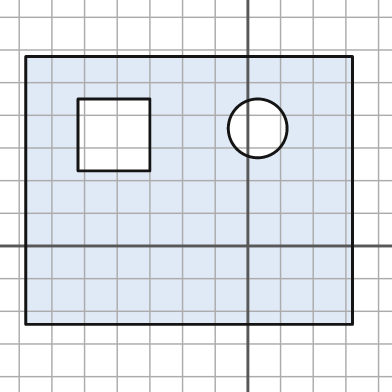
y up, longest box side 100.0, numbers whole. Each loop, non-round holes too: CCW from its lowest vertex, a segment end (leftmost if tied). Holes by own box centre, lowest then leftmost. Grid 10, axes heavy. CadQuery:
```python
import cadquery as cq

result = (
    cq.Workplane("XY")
    .moveTo(-68.0, -24.0)
    .lineTo(32.0, -24.0)
    .lineTo(32.0, 58.0)
    .lineTo(-68.0, 58.0)
    .close()
    .moveTo(-52.0, 23.0)
    .lineTo(-30.0, 23.0)
    .lineTo(-30.0, 45.0)
    .lineTo(-52.0, 45.0)
    .close()
    .moveTo(3.0, 36.0)
    .circle(9.0)
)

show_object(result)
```